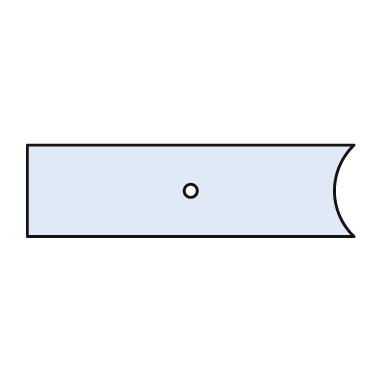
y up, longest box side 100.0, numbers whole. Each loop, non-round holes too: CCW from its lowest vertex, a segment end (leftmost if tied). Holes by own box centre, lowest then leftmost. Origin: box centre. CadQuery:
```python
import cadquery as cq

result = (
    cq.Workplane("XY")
    .moveTo(-50.0, -14.0)
    .lineTo(50.0, -14.0)
    .threePointArc((44.0, 0.0), (50.0, 14.0))
    .lineTo(-50.0, 14.0)
    .close()
    .moveTo(0.0, 0.0)
    .circle(2.0)
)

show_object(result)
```